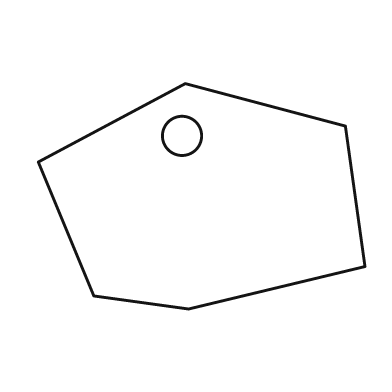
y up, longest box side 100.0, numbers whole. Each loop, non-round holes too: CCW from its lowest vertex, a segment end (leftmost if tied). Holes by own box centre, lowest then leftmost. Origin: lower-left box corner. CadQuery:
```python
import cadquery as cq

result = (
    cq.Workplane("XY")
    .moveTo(46.0, 0.0)
    .lineTo(100.0, 13.0)
    .lineTo(94.0, 56.0)
    .lineTo(45.0, 69.0)
    .lineTo(0.0, 45.0)
    .lineTo(17.0, 4.0)
    .close()
    .moveTo(44.0, 53.0)
    .circle(6.0)
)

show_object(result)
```